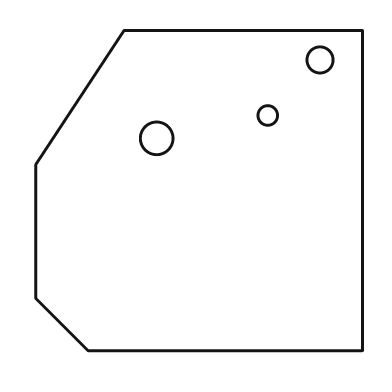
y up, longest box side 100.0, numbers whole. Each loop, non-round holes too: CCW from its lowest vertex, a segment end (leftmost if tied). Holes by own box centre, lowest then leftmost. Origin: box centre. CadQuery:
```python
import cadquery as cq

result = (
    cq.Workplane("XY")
    .moveTo(-34.0, -49.0)
    .lineTo(50.0, -49.0)
    .lineTo(50.0, 49.0)
    .lineTo(-23.0, 49.0)
    .lineTo(-50.0, 8.0)
    .lineTo(-50.0, -33.0)
    .close()
    .moveTo(-13.0, 16.0)
    .circle(5.0)
    .moveTo(21.0, 23.0)
    .circle(3.0)
    .moveTo(37.0, 40.0)
    .circle(4.0)
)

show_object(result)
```